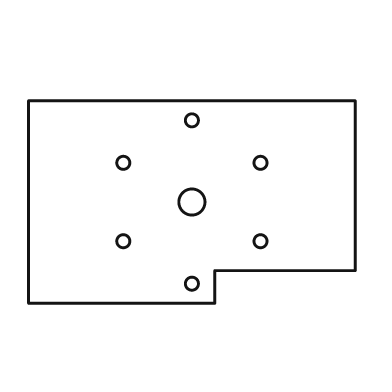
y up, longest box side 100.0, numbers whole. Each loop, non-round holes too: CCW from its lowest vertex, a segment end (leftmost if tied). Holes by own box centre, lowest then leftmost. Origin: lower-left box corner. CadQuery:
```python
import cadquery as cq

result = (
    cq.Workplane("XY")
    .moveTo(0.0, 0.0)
    .lineTo(57.0, 0.0)
    .lineTo(57.0, 10.0)
    .lineTo(100.0, 10.0)
    .lineTo(100.0, 62.0)
    .lineTo(0.0, 62.0)
    .close()
    .moveTo(50.0, 6.0)
    .circle(2.0)
    .moveTo(29.0, 19.0)
    .circle(2.0)
    .moveTo(71.0, 19.0)
    .circle(2.0)
    .moveTo(50.0, 31.0)
    .circle(4.0)
    .moveTo(29.0, 43.0)
    .circle(2.0)
    .moveTo(71.0, 43.0)
    .circle(2.0)
    .moveTo(50.0, 56.0)
    .circle(2.0)
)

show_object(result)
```